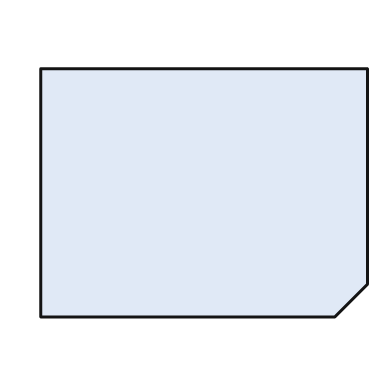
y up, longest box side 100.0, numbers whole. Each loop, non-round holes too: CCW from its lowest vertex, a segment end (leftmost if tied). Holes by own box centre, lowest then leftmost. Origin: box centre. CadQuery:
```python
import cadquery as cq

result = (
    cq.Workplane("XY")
    .moveTo(-50.0, -38.0)
    .lineTo(40.0, -38.0)
    .lineTo(50.0, -28.0)
    .lineTo(50.0, 38.0)
    .lineTo(-50.0, 38.0)
    .close()
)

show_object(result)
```